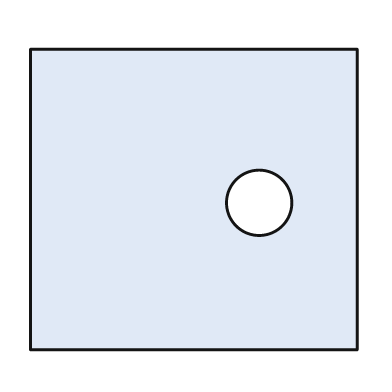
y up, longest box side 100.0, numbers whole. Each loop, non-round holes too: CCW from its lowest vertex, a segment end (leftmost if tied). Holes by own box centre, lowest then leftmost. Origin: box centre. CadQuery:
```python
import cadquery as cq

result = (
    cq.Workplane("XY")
    .moveTo(-50.0, -46.0)
    .lineTo(50.0, -46.0)
    .lineTo(50.0, 46.0)
    .lineTo(-50.0, 46.0)
    .close()
    .moveTo(20.0, -1.0)
    .circle(10.0)
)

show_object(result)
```